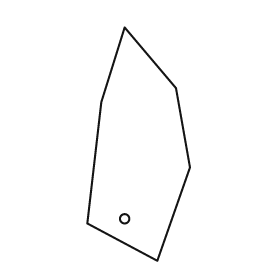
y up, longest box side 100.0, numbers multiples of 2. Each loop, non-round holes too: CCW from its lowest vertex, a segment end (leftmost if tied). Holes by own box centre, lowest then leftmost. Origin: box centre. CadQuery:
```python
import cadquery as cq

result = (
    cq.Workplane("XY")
    .moveTo(8.0, -50.0)
    .lineTo(22.0, -10.0)
    .lineTo(16.0, 24.0)
    .lineTo(-6.0, 50.0)
    .lineTo(-16.0, 18.0)
    .lineTo(-22.0, -34.0)
    .close()
    .moveTo(-6.0, -32.0)
    .circle(2.0)
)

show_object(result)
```